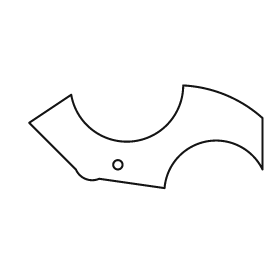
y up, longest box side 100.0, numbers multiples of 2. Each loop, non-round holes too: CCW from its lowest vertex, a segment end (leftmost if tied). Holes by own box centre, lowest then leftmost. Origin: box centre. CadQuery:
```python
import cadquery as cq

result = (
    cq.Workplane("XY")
    .moveTo(8.0, -22.0)
    .threePointArc((26.0, -2.0), (50.0, -14.0))
    .lineTo(50.0, 8.0)
    .threePointArc((34.0, 18.0), (16.0, 22.0))
    .threePointArc((-6.0, -2.0), (-32.0, 18.0))
    .lineTo(-50.0, 6.0)
    .lineTo(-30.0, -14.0)
    .threePointArc((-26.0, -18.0), (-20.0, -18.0))
    .close()
    .moveTo(-12.0, -12.0)
    .circle(2.0)
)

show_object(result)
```